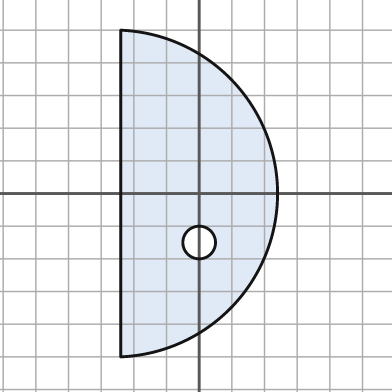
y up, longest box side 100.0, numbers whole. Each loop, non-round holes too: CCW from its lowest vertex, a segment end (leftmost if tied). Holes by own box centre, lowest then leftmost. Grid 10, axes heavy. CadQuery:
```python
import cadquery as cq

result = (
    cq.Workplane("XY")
    .moveTo(-24.0, -50.0)
    .threePointArc((24.0, 0.0), (-24.0, 50.0))
    .close()
    .moveTo(0.0, -15.0)
    .circle(5.0)
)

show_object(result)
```